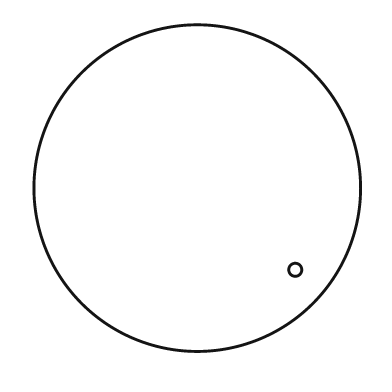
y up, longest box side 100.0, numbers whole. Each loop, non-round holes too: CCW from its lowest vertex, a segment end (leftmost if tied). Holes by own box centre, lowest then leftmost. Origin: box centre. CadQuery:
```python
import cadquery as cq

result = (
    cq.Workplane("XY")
    .moveTo(0.0, 0.0)
    .circle(50.0)
    .moveTo(30.0, -25.0)
    .circle(2.0)
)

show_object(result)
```